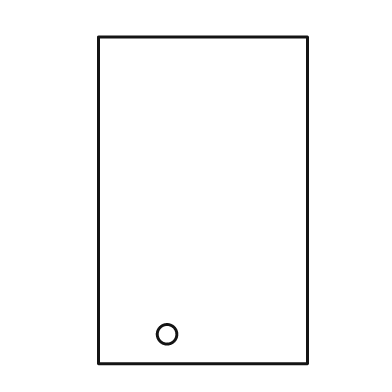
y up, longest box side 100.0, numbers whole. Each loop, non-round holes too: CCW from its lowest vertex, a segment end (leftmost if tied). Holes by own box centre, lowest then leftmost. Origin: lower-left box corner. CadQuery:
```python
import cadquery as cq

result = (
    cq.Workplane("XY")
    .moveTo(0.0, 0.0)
    .lineTo(64.0, 0.0)
    .lineTo(64.0, 100.0)
    .lineTo(0.0, 100.0)
    .close()
    .moveTo(21.0, 9.0)
    .circle(3.0)
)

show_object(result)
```